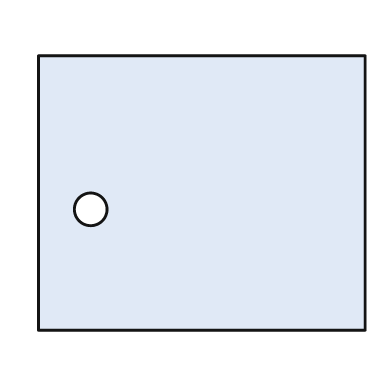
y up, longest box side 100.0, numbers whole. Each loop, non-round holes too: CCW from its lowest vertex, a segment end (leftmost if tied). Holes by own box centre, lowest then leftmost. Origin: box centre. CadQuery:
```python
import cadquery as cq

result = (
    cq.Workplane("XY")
    .moveTo(-50.0, -42.0)
    .lineTo(50.0, -42.0)
    .lineTo(50.0, 42.0)
    .lineTo(-50.0, 42.0)
    .close()
    .moveTo(-34.0, -5.0)
    .circle(5.0)
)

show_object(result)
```